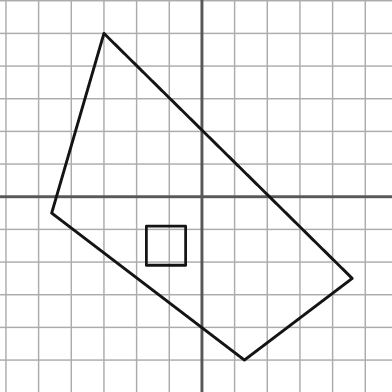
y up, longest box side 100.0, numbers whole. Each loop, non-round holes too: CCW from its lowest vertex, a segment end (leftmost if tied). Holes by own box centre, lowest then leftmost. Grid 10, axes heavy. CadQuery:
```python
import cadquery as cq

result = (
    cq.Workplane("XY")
    .moveTo(13.0, -50.0)
    .lineTo(46.0, -25.0)
    .lineTo(-30.0, 50.0)
    .lineTo(-46.0, -5.0)
    .close()
    .moveTo(-17.0, -21.0)
    .lineTo(-5.0, -21.0)
    .lineTo(-5.0, -9.0)
    .lineTo(-17.0, -9.0)
    .close()
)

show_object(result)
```